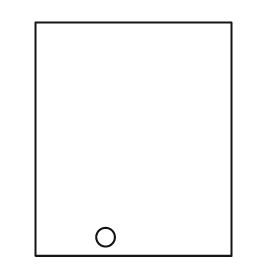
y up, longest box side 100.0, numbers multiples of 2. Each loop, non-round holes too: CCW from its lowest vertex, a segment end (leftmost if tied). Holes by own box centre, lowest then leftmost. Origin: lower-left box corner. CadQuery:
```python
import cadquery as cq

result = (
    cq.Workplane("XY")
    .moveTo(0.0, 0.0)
    .lineTo(84.0, 0.0)
    .lineTo(84.0, 100.0)
    .lineTo(0.0, 100.0)
    .close()
    .moveTo(30.0, 8.0)
    .circle(4.0)
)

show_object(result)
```